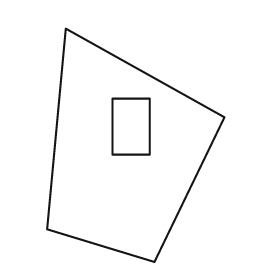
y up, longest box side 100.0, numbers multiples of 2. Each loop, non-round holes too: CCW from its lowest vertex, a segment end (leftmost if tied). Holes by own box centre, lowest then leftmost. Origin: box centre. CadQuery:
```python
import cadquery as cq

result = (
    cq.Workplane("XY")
    .moveTo(8.0, -50.0)
    .lineTo(38.0, 12.0)
    .lineTo(-30.0, 50.0)
    .lineTo(-38.0, -36.0)
    .close()
    .moveTo(-10.0, -4.0)
    .lineTo(6.0, -4.0)
    .lineTo(6.0, 20.0)
    .lineTo(-10.0, 20.0)
    .close()
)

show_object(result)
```